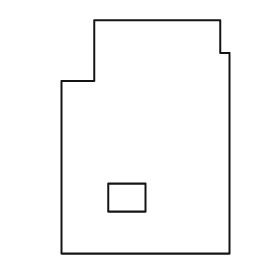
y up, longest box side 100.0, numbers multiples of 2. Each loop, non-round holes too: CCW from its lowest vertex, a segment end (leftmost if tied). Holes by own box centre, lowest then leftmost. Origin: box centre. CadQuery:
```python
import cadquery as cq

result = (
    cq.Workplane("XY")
    .moveTo(-36.0, -50.0)
    .lineTo(36.0, -50.0)
    .lineTo(36.0, 36.0)
    .lineTo(32.0, 36.0)
    .lineTo(32.0, 50.0)
    .lineTo(-22.0, 50.0)
    .lineTo(-22.0, 24.0)
    .lineTo(-36.0, 24.0)
    .close()
    .moveTo(-16.0, -32.0)
    .lineTo(0.0, -32.0)
    .lineTo(0.0, -20.0)
    .lineTo(-16.0, -20.0)
    .close()
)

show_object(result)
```